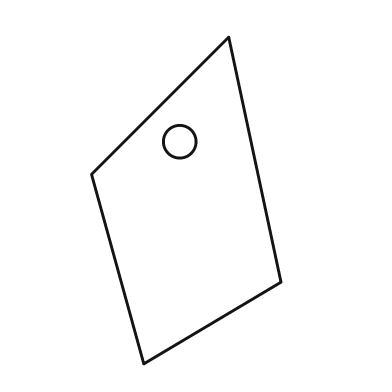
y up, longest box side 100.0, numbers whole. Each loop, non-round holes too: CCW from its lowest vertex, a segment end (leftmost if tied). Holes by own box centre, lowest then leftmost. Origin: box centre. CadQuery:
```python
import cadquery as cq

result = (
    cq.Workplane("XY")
    .moveTo(-13.0, -50.0)
    .lineTo(29.0, -25.0)
    .lineTo(13.0, 50.0)
    .lineTo(-29.0, 8.0)
    .close()
    .moveTo(-2.0, 18.0)
    .circle(5.0)
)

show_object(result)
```